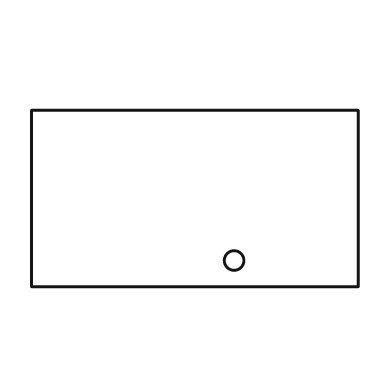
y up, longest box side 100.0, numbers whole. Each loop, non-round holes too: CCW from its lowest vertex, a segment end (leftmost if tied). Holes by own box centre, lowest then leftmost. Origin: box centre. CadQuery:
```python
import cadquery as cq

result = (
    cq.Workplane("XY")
    .moveTo(-50.0, -27.0)
    .lineTo(50.0, -27.0)
    .lineTo(50.0, 27.0)
    .lineTo(-50.0, 27.0)
    .close()
    .moveTo(12.0, -19.0)
    .circle(3.0)
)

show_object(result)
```